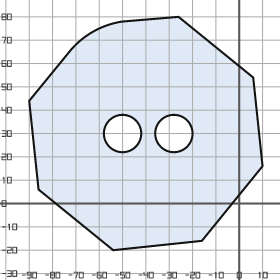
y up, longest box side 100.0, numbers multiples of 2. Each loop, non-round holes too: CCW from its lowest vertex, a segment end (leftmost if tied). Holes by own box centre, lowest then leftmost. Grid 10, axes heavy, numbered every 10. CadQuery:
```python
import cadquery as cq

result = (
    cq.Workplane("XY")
    .moveTo(-54.0, -20.0)
    .lineTo(-16.0, -16.0)
    .lineTo(10.0, 16.0)
    .lineTo(6.0, 54.0)
    .lineTo(-26.0, 80.0)
    .lineTo(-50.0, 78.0)
    .threePointArc((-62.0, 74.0), (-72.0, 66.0))
    .lineTo(-90.0, 44.0)
    .lineTo(-86.0, 6.0)
    .close()
    .moveTo(-50.0, 30.0)
    .circle(8.0)
    .moveTo(-28.0, 30.0)
    .circle(8.0)
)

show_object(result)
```